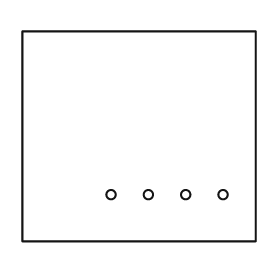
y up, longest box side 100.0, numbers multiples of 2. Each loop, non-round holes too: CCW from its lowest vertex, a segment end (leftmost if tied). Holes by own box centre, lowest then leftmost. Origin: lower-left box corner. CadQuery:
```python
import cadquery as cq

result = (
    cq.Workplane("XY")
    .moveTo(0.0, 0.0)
    .lineTo(100.0, 0.0)
    .lineTo(100.0, 90.0)
    .lineTo(0.0, 90.0)
    .close()
    .moveTo(38.0, 20.0)
    .circle(2.0)
    .moveTo(54.0, 20.0)
    .circle(2.0)
    .moveTo(70.0, 20.0)
    .circle(2.0)
    .moveTo(86.0, 20.0)
    .circle(2.0)
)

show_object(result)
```